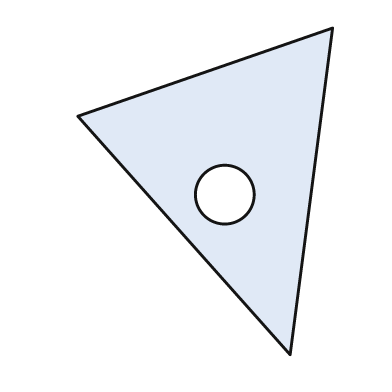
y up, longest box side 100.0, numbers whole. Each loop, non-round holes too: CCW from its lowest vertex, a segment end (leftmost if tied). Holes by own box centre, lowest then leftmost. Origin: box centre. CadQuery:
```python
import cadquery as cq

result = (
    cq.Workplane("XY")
    .moveTo(26.0, -50.0)
    .lineTo(39.0, 50.0)
    .lineTo(-39.0, 23.0)
    .close()
    .moveTo(6.0, -1.0)
    .circle(9.0)
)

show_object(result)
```